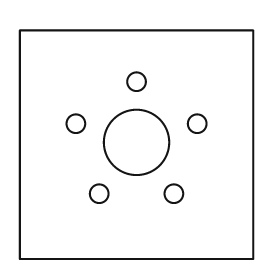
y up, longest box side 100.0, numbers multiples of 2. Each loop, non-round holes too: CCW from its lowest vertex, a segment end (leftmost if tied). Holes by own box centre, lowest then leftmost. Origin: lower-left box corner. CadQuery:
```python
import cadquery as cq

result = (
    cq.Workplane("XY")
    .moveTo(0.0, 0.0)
    .lineTo(100.0, 0.0)
    .lineTo(100.0, 98.0)
    .lineTo(0.0, 98.0)
    .close()
    .moveTo(34.0, 28.0)
    .circle(4.0)
    .moveTo(66.0, 28.0)
    .circle(4.0)
    .moveTo(50.0, 50.0)
    .circle(14.0)
    .moveTo(24.0, 58.0)
    .circle(4.0)
    .moveTo(76.0, 58.0)
    .circle(4.0)
    .moveTo(50.0, 76.0)
    .circle(4.0)
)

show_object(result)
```